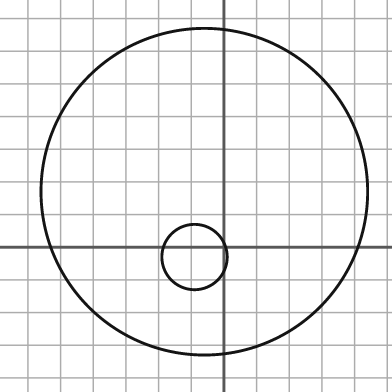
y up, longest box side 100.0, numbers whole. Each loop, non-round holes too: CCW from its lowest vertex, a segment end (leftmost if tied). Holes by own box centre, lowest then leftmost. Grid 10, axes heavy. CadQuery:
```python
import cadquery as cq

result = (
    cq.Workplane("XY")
    .moveTo(-6.0, 17.0)
    .circle(50.0)
    .moveTo(-9.0, -3.0)
    .circle(10.0)
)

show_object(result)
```